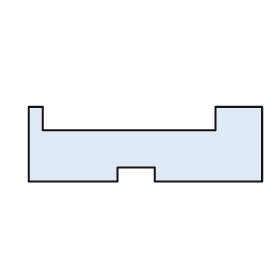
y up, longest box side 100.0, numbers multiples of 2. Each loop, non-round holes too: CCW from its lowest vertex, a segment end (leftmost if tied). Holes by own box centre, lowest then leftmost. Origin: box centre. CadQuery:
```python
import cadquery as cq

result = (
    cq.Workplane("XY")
    .moveTo(-50.0, -16.0)
    .lineTo(-12.0, -16.0)
    .lineTo(-12.0, -10.0)
    .lineTo(4.0, -10.0)
    .lineTo(4.0, -16.0)
    .lineTo(50.0, -16.0)
    .lineTo(50.0, 16.0)
    .lineTo(30.0, 16.0)
    .lineTo(30.0, 6.0)
    .lineTo(-44.0, 6.0)
    .lineTo(-44.0, 16.0)
    .lineTo(-50.0, 16.0)
    .close()
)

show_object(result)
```